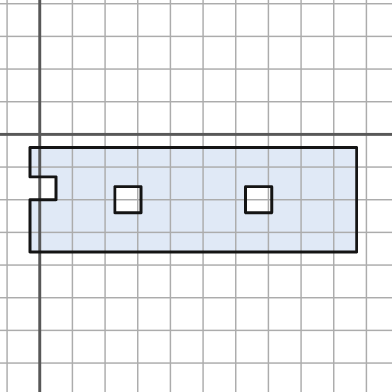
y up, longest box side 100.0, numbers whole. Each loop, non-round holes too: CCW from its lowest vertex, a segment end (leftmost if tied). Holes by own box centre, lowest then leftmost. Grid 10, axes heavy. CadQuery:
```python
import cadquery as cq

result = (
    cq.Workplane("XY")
    .moveTo(-3.0, -36.0)
    .lineTo(97.0, -36.0)
    .lineTo(97.0, -4.0)
    .lineTo(-3.0, -4.0)
    .lineTo(-3.0, -13.0)
    .lineTo(5.0, -13.0)
    .lineTo(5.0, -20.0)
    .lineTo(-3.0, -20.0)
    .close()
    .moveTo(23.0, -24.0)
    .lineTo(31.0, -24.0)
    .lineTo(31.0, -16.0)
    .lineTo(23.0, -16.0)
    .close()
    .moveTo(63.0, -24.0)
    .lineTo(71.0, -24.0)
    .lineTo(71.0, -16.0)
    .lineTo(63.0, -16.0)
    .close()
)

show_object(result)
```